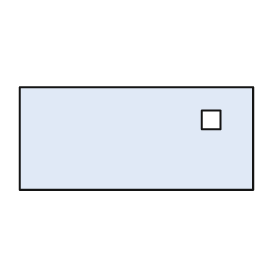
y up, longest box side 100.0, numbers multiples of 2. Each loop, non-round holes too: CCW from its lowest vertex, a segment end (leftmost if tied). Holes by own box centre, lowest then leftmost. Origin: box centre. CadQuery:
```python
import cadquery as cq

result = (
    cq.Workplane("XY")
    .moveTo(-50.0, -22.0)
    .lineTo(50.0, -22.0)
    .lineTo(50.0, 22.0)
    .lineTo(-50.0, 22.0)
    .close()
    .moveTo(28.0, 4.0)
    .lineTo(36.0, 4.0)
    .lineTo(36.0, 12.0)
    .lineTo(28.0, 12.0)
    .close()
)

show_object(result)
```